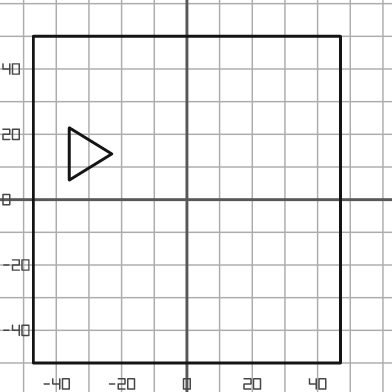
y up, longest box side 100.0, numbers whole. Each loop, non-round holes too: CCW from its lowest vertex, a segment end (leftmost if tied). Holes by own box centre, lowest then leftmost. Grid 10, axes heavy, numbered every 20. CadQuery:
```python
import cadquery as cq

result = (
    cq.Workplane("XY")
    .moveTo(-47.0, -50.0)
    .lineTo(47.0, -50.0)
    .lineTo(47.0, 50.0)
    .lineTo(-47.0, 50.0)
    .close()
    .moveTo(-36.0, 6.0)
    .lineTo(-23.0, 14.0)
    .lineTo(-36.0, 22.0)
    .close()
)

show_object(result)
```